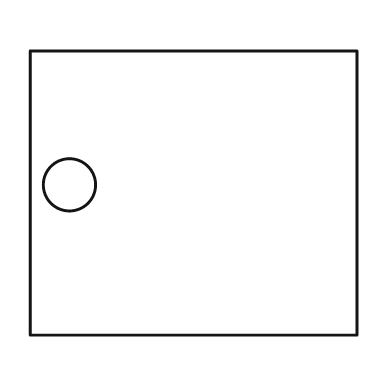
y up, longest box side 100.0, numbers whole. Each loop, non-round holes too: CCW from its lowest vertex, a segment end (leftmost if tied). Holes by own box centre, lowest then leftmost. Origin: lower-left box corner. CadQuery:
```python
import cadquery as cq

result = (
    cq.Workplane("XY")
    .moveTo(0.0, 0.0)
    .lineTo(100.0, 0.0)
    .lineTo(100.0, 87.0)
    .lineTo(0.0, 87.0)
    .close()
    .moveTo(12.0, 46.0)
    .circle(8.0)
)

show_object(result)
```